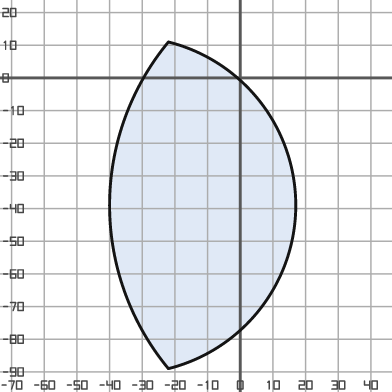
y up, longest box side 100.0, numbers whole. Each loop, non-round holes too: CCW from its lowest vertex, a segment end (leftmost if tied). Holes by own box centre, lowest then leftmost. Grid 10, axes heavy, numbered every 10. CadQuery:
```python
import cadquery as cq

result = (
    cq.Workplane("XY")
    .moveTo(-22.0, -89.0)
    .threePointArc((17.0, -39.0), (-22.0, 11.0))
    .threePointArc((-40.0, -39.0), (-22.0, -89.0))
    .close()
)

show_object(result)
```